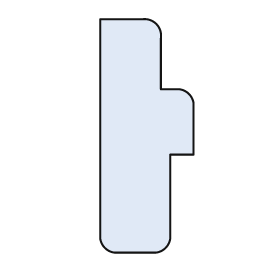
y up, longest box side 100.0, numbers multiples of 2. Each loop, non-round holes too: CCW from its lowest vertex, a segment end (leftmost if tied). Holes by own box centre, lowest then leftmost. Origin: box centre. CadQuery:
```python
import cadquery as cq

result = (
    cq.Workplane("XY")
    .moveTo(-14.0, -50.0)
    .lineTo(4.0, -50.0)
    .threePointArc((8.0, -48.0), (10.0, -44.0))
    .lineTo(10.0, -8.0)
    .lineTo(20.0, -8.0)
    .lineTo(20.0, 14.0)
    .threePointArc((18.0, 18.0), (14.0, 20.0))
    .lineTo(6.0, 20.0)
    .lineTo(6.0, 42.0)
    .threePointArc((4.0, 48.0), (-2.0, 50.0))
    .lineTo(-20.0, 50.0)
    .lineTo(-20.0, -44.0)
    .threePointArc((-18.0, -48.0), (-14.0, -50.0))
    .close()
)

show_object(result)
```